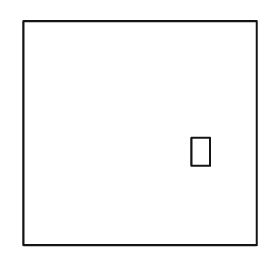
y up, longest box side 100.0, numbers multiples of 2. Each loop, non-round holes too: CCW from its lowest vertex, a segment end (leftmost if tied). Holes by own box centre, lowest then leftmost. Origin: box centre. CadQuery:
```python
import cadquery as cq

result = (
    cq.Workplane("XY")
    .moveTo(-50.0, -48.0)
    .lineTo(50.0, -48.0)
    .lineTo(50.0, 48.0)
    .lineTo(-50.0, 48.0)
    .close()
    .moveTo(22.0, -14.0)
    .lineTo(30.0, -14.0)
    .lineTo(30.0, -2.0)
    .lineTo(22.0, -2.0)
    .close()
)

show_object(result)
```